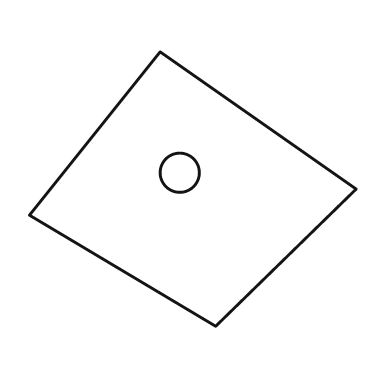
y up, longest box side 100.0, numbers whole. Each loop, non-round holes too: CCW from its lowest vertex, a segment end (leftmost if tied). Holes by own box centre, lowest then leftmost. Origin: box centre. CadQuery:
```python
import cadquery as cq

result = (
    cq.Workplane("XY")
    .moveTo(7.0, -42.0)
    .lineTo(50.0, 0.0)
    .lineTo(-10.0, 42.0)
    .lineTo(-50.0, -8.0)
    .close()
    .moveTo(-4.0, 5.0)
    .circle(6.0)
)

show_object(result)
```